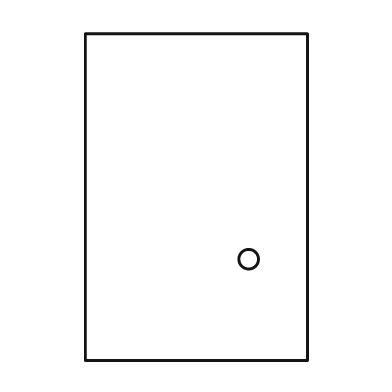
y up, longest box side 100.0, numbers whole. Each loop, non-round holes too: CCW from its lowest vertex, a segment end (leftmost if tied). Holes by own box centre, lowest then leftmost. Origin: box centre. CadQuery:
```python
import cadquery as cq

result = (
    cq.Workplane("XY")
    .moveTo(-34.0, -50.0)
    .lineTo(34.0, -50.0)
    .lineTo(34.0, 50.0)
    .lineTo(-34.0, 50.0)
    .close()
    .moveTo(16.0, -19.0)
    .circle(3.0)
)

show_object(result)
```